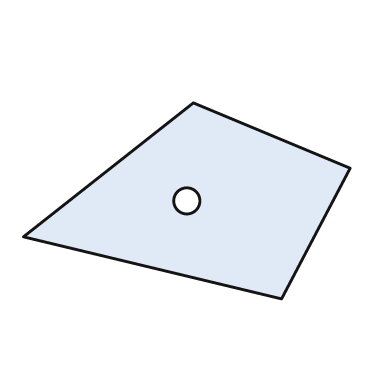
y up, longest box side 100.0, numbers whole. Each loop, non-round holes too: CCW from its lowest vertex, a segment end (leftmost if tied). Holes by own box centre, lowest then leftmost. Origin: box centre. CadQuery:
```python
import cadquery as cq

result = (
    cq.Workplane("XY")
    .moveTo(29.0, -30.0)
    .lineTo(50.0, 10.0)
    .lineTo(2.0, 30.0)
    .lineTo(-50.0, -11.0)
    .close()
    .moveTo(0.0, 0.0)
    .circle(4.0)
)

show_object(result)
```